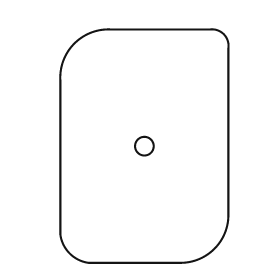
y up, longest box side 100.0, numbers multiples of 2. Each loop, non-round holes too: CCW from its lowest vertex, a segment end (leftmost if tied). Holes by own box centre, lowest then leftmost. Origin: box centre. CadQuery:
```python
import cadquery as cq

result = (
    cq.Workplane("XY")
    .moveTo(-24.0, -50.0)
    .lineTo(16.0, -50.0)
    .threePointArc((30.0, -44.0), (36.0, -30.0))
    .lineTo(36.0, 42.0)
    .threePointArc((34.0, 48.0), (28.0, 50.0))
    .lineTo(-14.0, 50.0)
    .threePointArc((-30.0, 44.0), (-36.0, 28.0))
    .lineTo(-36.0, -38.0)
    .threePointArc((-32.0, -46.0), (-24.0, -50.0))
    .close()
    .moveTo(0.0, 0.0)
    .circle(4.0)
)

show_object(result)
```